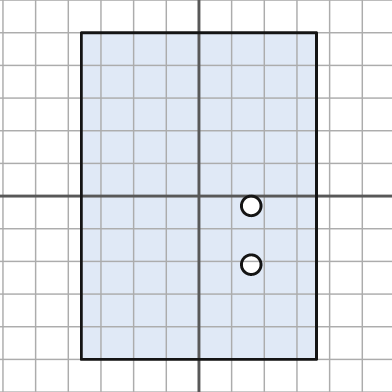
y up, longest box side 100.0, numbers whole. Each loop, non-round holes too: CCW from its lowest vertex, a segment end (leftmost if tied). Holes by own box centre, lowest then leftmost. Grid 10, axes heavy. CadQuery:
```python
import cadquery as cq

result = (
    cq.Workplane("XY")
    .moveTo(-36.0, -50.0)
    .lineTo(36.0, -50.0)
    .lineTo(36.0, 50.0)
    .lineTo(-36.0, 50.0)
    .close()
    .moveTo(16.0, -21.0)
    .circle(3.0)
    .moveTo(16.0, -3.0)
    .circle(3.0)
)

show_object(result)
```